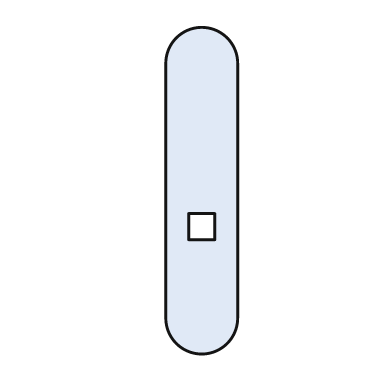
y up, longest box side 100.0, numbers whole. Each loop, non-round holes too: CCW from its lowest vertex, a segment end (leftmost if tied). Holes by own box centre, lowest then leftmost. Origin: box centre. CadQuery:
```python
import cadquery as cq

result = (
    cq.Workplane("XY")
    .moveTo(-11.0, -39.0)
    .threePointArc((0.0, -50.0), (11.0, -39.0))
    .lineTo(11.0, 39.0)
    .threePointArc((0.0, 50.0), (-11.0, 39.0))
    .close()
    .moveTo(-4.0, -15.0)
    .lineTo(4.0, -15.0)
    .lineTo(4.0, -7.0)
    .lineTo(-4.0, -7.0)
    .close()
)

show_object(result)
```